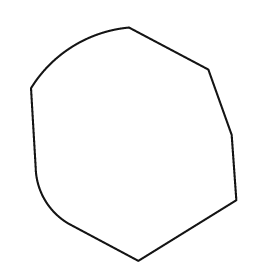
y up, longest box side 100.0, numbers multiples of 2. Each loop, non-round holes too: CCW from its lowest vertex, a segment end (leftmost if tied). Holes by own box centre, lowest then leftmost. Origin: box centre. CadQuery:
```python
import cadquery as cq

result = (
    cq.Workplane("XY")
    .moveTo(2.0, -50.0)
    .lineTo(44.0, -24.0)
    .lineTo(42.0, 4.0)
    .lineTo(32.0, 32.0)
    .lineTo(-2.0, 50.0)
    .threePointArc((-26.0, 42.0), (-44.0, 24.0))
    .lineTo(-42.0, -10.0)
    .threePointArc((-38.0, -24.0), (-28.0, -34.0))
    .close()
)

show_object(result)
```